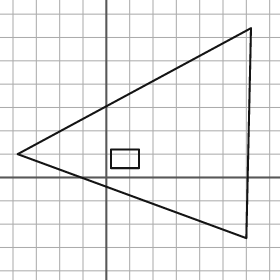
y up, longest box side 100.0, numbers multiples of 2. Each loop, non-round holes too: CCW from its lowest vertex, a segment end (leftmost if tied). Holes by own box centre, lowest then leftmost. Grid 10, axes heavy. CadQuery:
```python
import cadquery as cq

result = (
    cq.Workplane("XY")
    .moveTo(60.0, -26.0)
    .lineTo(62.0, 64.0)
    .lineTo(-38.0, 10.0)
    .close()
    .moveTo(2.0, 4.0)
    .lineTo(14.0, 4.0)
    .lineTo(14.0, 12.0)
    .lineTo(2.0, 12.0)
    .close()
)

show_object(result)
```